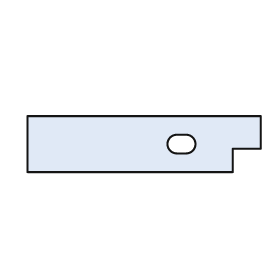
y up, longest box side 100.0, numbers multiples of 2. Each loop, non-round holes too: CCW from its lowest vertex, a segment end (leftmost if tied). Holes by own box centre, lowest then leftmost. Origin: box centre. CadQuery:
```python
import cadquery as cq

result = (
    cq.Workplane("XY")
    .moveTo(-50.0, -12.0)
    .lineTo(38.0, -12.0)
    .lineTo(38.0, -2.0)
    .lineTo(50.0, -2.0)
    .lineTo(50.0, 12.0)
    .lineTo(-50.0, 12.0)
    .close()
    .moveTo(14.0, -4.0)
    .lineTo(18.0, -4.0)
    .threePointArc((22.0, 0.0), (18.0, 4.0))
    .lineTo(14.0, 4.0)
    .threePointArc((10.0, 0.0), (14.0, -4.0))
    .close()
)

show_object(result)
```